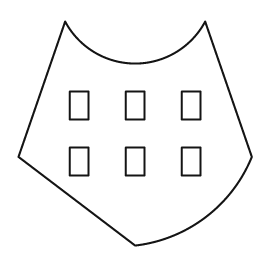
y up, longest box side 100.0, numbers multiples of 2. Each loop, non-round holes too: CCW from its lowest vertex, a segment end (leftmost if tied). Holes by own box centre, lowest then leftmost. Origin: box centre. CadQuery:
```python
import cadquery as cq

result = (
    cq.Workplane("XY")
    .moveTo(0.0, -48.0)
    .threePointArc((30.0, -36.0), (50.0, -10.0))
    .lineTo(30.0, 48.0)
    .threePointArc((0.0, 30.0), (-30.0, 48.0))
    .lineTo(-50.0, -10.0)
    .close()
    .moveTo(-28.0, -18.0)
    .lineTo(-20.0, -18.0)
    .lineTo(-20.0, -6.0)
    .lineTo(-28.0, -6.0)
    .close()
    .moveTo(-4.0, -18.0)
    .lineTo(4.0, -18.0)
    .lineTo(4.0, -6.0)
    .lineTo(-4.0, -6.0)
    .close()
    .moveTo(20.0, -18.0)
    .lineTo(28.0, -18.0)
    .lineTo(28.0, -6.0)
    .lineTo(20.0, -6.0)
    .close()
    .moveTo(-28.0, 6.0)
    .lineTo(-20.0, 6.0)
    .lineTo(-20.0, 18.0)
    .lineTo(-28.0, 18.0)
    .close()
    .moveTo(-4.0, 6.0)
    .lineTo(4.0, 6.0)
    .lineTo(4.0, 18.0)
    .lineTo(-4.0, 18.0)
    .close()
    .moveTo(20.0, 6.0)
    .lineTo(28.0, 6.0)
    .lineTo(28.0, 18.0)
    .lineTo(20.0, 18.0)
    .close()
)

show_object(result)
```